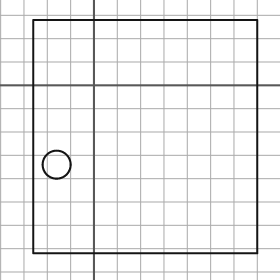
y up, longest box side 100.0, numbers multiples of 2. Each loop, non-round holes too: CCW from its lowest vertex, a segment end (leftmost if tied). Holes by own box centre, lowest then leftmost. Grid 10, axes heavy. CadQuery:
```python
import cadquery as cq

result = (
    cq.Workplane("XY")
    .moveTo(-26.0, -72.0)
    .lineTo(70.0, -72.0)
    .lineTo(70.0, 28.0)
    .lineTo(-26.0, 28.0)
    .close()
    .moveTo(-16.0, -34.0)
    .circle(6.0)
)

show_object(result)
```